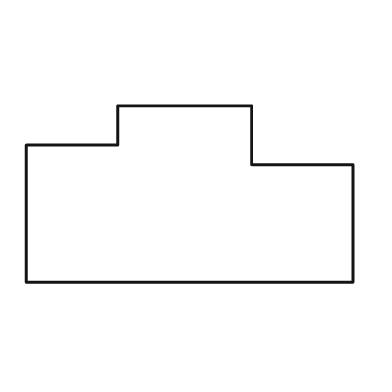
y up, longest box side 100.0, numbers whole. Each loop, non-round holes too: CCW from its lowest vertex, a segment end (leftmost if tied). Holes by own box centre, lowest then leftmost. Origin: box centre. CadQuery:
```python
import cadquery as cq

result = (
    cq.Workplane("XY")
    .moveTo(-50.0, -27.0)
    .lineTo(50.0, -27.0)
    .lineTo(50.0, 9.0)
    .lineTo(19.0, 9.0)
    .lineTo(19.0, 27.0)
    .lineTo(-22.0, 27.0)
    .lineTo(-22.0, 15.0)
    .lineTo(-50.0, 15.0)
    .close()
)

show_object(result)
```